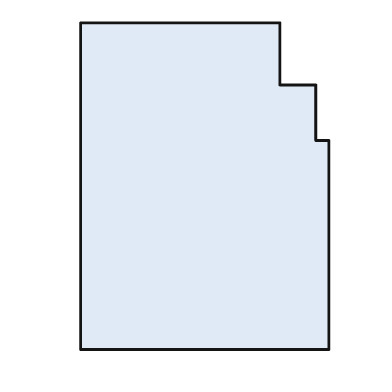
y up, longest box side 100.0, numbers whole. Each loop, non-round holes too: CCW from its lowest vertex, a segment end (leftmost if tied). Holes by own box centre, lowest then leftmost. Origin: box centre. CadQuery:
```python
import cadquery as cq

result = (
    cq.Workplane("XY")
    .moveTo(-38.0, -50.0)
    .lineTo(38.0, -50.0)
    .lineTo(38.0, 14.0)
    .lineTo(34.0, 14.0)
    .lineTo(34.0, 31.0)
    .lineTo(23.0, 31.0)
    .lineTo(23.0, 50.0)
    .lineTo(-38.0, 50.0)
    .close()
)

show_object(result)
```